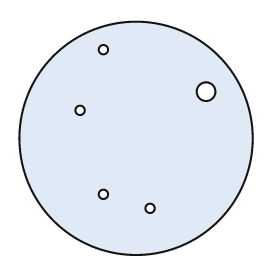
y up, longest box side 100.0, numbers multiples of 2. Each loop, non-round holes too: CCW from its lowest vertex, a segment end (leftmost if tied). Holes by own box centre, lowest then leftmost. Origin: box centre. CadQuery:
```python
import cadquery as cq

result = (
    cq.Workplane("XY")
    .moveTo(0.0, 0.0)
    .circle(50.0)
    .moveTo(6.0, -30.0)
    .circle(2.0)
    .moveTo(-14.0, -24.0)
    .circle(2.0)
    .moveTo(-24.0, 12.0)
    .circle(2.0)
    .moveTo(30.0, 20.0)
    .circle(4.0)
    .moveTo(-14.0, 38.0)
    .circle(2.0)
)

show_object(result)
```